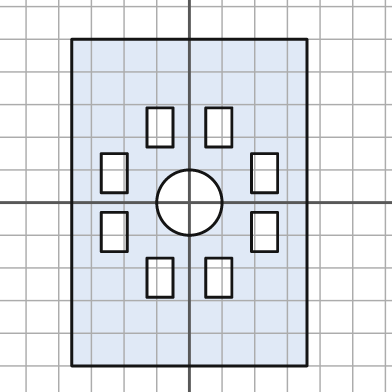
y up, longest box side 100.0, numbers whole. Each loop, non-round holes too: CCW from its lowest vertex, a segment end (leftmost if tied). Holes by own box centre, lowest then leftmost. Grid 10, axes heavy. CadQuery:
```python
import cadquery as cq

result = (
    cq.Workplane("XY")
    .moveTo(-36.0, -50.0)
    .lineTo(36.0, -50.0)
    .lineTo(36.0, 50.0)
    .lineTo(-36.0, 50.0)
    .close()
    .moveTo(-13.0, -29.0)
    .lineTo(-5.0, -29.0)
    .lineTo(-5.0, -17.0)
    .lineTo(-13.0, -17.0)
    .close()
    .moveTo(5.0, -29.0)
    .lineTo(13.0, -29.0)
    .lineTo(13.0, -17.0)
    .lineTo(5.0, -17.0)
    .close()
    .moveTo(-27.0, -15.0)
    .lineTo(-19.0, -15.0)
    .lineTo(-19.0, -3.0)
    .lineTo(-27.0, -3.0)
    .close()
    .moveTo(19.0, -15.0)
    .lineTo(27.0, -15.0)
    .lineTo(27.0, -3.0)
    .lineTo(19.0, -3.0)
    .close()
    .moveTo(0.0, 0.0)
    .circle(10.0)
    .moveTo(-27.0, 3.0)
    .lineTo(-19.0, 3.0)
    .lineTo(-19.0, 15.0)
    .lineTo(-27.0, 15.0)
    .close()
    .moveTo(19.0, 3.0)
    .lineTo(27.0, 3.0)
    .lineTo(27.0, 15.0)
    .lineTo(19.0, 15.0)
    .close()
    .moveTo(-13.0, 17.0)
    .lineTo(-5.0, 17.0)
    .lineTo(-5.0, 29.0)
    .lineTo(-13.0, 29.0)
    .close()
    .moveTo(5.0, 17.0)
    .lineTo(13.0, 17.0)
    .lineTo(13.0, 29.0)
    .lineTo(5.0, 29.0)
    .close()
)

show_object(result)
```